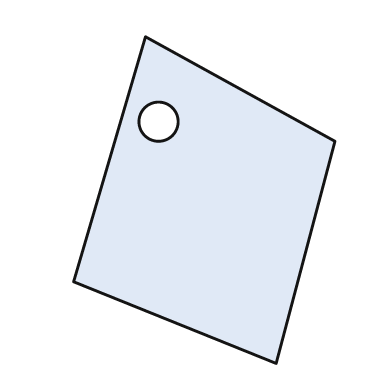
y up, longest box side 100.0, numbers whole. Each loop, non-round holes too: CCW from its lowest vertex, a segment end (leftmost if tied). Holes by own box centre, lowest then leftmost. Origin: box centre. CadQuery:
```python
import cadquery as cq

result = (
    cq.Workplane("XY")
    .moveTo(22.0, -50.0)
    .lineTo(40.0, 18.0)
    .lineTo(-18.0, 50.0)
    .lineTo(-40.0, -25.0)
    .close()
    .moveTo(-14.0, 24.0)
    .circle(6.0)
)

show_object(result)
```